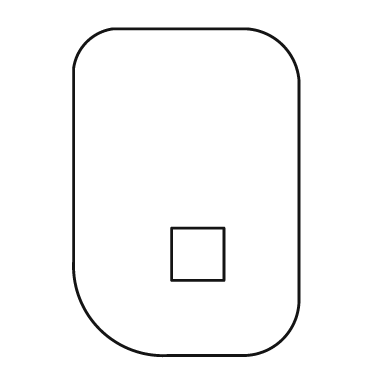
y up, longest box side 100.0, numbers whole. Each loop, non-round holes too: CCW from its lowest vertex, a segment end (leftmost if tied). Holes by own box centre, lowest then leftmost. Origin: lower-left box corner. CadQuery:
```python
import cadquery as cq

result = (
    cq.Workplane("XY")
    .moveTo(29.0, 0.0)
    .lineTo(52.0, 0.0)
    .threePointArc((64.0, 5.0), (69.0, 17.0))
    .lineTo(69.0, 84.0)
    .threePointArc((64.0, 95.0), (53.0, 100.0))
    .lineTo(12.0, 100.0)
    .threePointArc((4.0, 96.0), (0.0, 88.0))
    .lineTo(0.0, 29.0)
    .threePointArc((8.0, 8.0), (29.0, 0.0))
    .close()
    .moveTo(30.0, 23.0)
    .lineTo(46.0, 23.0)
    .lineTo(46.0, 39.0)
    .lineTo(30.0, 39.0)
    .close()
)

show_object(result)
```